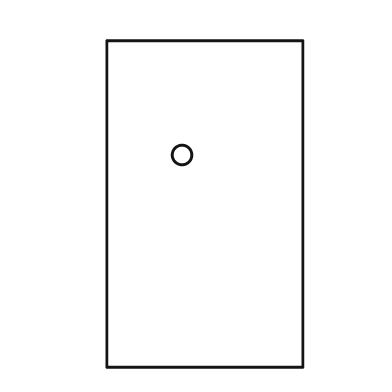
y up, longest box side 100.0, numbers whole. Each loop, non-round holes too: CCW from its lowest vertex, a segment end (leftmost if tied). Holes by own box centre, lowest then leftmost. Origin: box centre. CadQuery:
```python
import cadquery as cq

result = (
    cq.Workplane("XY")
    .moveTo(-30.0, -50.0)
    .lineTo(30.0, -50.0)
    .lineTo(30.0, 50.0)
    .lineTo(-30.0, 50.0)
    .close()
    .moveTo(-7.0, 15.0)
    .circle(3.0)
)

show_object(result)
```